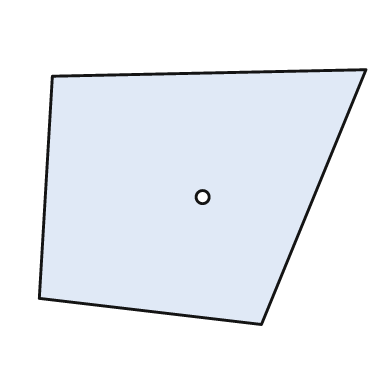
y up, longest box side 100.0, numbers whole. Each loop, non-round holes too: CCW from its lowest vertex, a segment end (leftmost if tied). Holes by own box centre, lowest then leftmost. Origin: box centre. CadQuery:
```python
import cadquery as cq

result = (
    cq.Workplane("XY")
    .moveTo(18.0, -39.0)
    .lineTo(50.0, 39.0)
    .lineTo(-46.0, 37.0)
    .lineTo(-50.0, -31.0)
    .close()
    .moveTo(0.0, 0.0)
    .circle(2.0)
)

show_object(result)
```